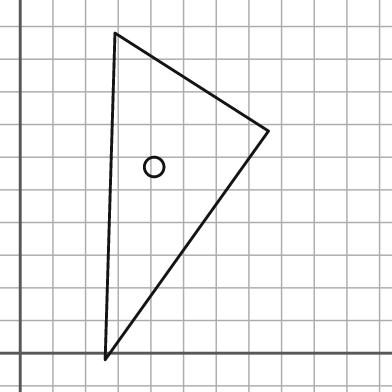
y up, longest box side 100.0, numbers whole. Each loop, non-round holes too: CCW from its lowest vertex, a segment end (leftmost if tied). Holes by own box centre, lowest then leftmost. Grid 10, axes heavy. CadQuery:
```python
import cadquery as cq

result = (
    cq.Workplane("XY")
    .moveTo(26.0, -2.0)
    .lineTo(76.0, 68.0)
    .lineTo(29.0, 98.0)
    .close()
    .moveTo(41.0, 57.0)
    .circle(3.0)
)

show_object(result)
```